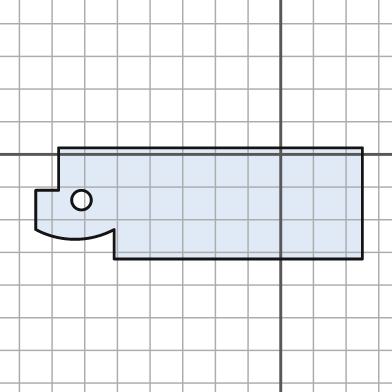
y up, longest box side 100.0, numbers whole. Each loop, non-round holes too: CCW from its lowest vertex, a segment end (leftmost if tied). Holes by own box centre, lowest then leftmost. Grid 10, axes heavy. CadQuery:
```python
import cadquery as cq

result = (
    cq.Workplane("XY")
    .moveTo(-51.0, -32.0)
    .lineTo(25.0, -32.0)
    .lineTo(25.0, 2.0)
    .lineTo(-68.0, 2.0)
    .lineTo(-68.0, -11.0)
    .lineTo(-75.0, -11.0)
    .lineTo(-75.0, -23.0)
    .threePointArc((-63.0, -26.0), (-51.0, -23.0))
    .close()
    .moveTo(-61.0, -14.0)
    .circle(3.0)
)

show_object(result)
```